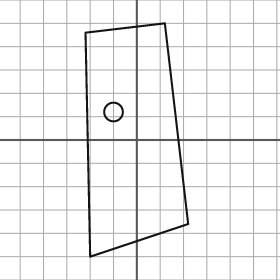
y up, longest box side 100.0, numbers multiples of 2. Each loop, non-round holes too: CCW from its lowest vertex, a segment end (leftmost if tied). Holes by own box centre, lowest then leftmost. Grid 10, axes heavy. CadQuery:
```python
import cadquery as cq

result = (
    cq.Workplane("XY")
    .moveTo(-20.0, -50.0)
    .lineTo(22.0, -36.0)
    .lineTo(12.0, 50.0)
    .lineTo(-22.0, 46.0)
    .close()
    .moveTo(-10.0, 12.0)
    .circle(4.0)
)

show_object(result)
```